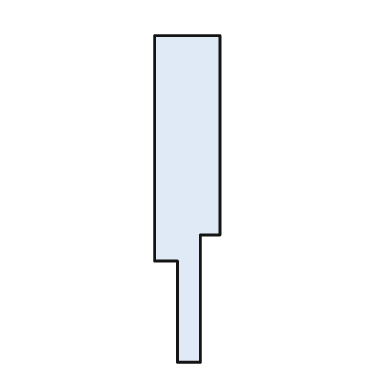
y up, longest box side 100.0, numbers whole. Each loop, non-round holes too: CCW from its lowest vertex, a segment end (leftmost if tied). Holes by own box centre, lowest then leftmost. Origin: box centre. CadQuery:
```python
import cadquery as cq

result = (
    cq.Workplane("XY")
    .moveTo(-3.0, -50.0)
    .lineTo(4.0, -50.0)
    .lineTo(4.0, -11.0)
    .lineTo(10.0, -11.0)
    .lineTo(10.0, 50.0)
    .lineTo(-10.0, 50.0)
    .lineTo(-10.0, -19.0)
    .lineTo(-3.0, -19.0)
    .close()
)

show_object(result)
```